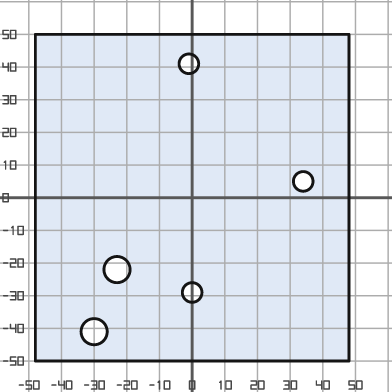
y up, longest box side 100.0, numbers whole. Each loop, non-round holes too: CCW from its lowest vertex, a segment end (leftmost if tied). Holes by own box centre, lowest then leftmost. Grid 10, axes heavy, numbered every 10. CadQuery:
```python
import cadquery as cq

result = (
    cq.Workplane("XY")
    .moveTo(-48.0, -50.0)
    .lineTo(48.0, -50.0)
    .lineTo(48.0, 50.0)
    .lineTo(-48.0, 50.0)
    .close()
    .moveTo(-30.0, -41.0)
    .circle(4.0)
    .moveTo(0.0, -29.0)
    .circle(3.0)
    .moveTo(-23.0, -22.0)
    .circle(4.0)
    .moveTo(34.0, 5.0)
    .circle(3.0)
    .moveTo(-1.0, 41.0)
    .circle(3.0)
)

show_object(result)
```